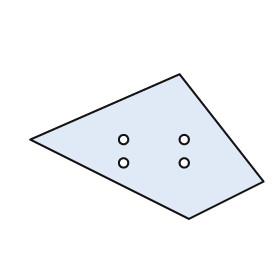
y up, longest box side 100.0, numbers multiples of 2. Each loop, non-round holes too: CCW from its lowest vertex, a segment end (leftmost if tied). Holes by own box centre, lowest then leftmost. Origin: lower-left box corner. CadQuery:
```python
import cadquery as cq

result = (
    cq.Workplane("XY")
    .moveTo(68.0, 0.0)
    .lineTo(100.0, 16.0)
    .lineTo(64.0, 62.0)
    .lineTo(0.0, 34.0)
    .close()
    .moveTo(40.0, 24.0)
    .circle(2.0)
    .moveTo(66.0, 24.0)
    .circle(2.0)
    .moveTo(40.0, 34.0)
    .circle(2.0)
    .moveTo(66.0, 34.0)
    .circle(2.0)
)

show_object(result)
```